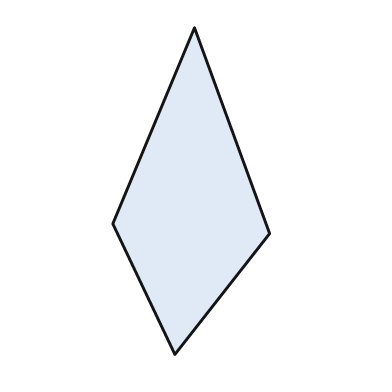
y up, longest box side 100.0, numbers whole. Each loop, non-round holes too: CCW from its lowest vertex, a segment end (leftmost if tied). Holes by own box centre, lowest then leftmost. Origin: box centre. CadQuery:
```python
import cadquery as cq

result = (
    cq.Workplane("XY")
    .moveTo(-5.0, -50.0)
    .lineTo(24.0, -13.0)
    .lineTo(1.0, 50.0)
    .lineTo(-24.0, -10.0)
    .close()
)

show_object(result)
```